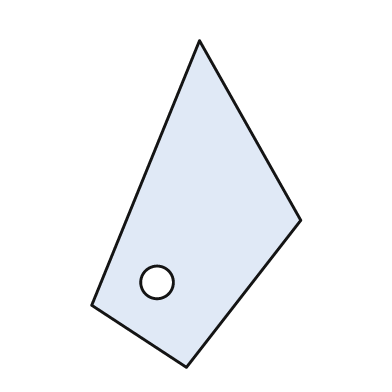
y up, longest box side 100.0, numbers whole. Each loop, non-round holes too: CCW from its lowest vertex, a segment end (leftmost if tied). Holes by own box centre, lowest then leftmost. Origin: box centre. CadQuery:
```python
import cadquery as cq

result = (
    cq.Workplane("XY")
    .moveTo(-3.0, -50.0)
    .lineTo(32.0, -5.0)
    .lineTo(1.0, 50.0)
    .lineTo(-32.0, -31.0)
    .close()
    .moveTo(-12.0, -24.0)
    .circle(5.0)
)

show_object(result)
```